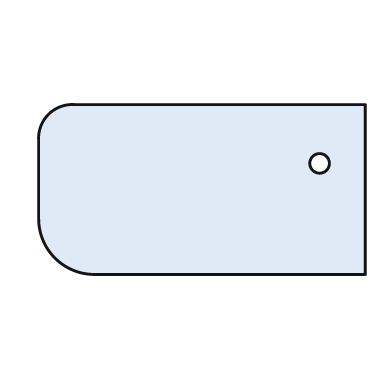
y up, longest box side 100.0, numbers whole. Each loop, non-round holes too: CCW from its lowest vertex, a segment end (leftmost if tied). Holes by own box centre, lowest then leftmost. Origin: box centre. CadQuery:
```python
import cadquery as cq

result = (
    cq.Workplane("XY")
    .moveTo(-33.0, -26.0)
    .lineTo(50.0, -26.0)
    .lineTo(50.0, 26.0)
    .lineTo(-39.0, 26.0)
    .threePointArc((-47.0, 23.0), (-50.0, 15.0))
    .lineTo(-50.0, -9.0)
    .threePointArc((-45.0, -21.0), (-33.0, -26.0))
    .close()
    .moveTo(36.0, 8.0)
    .circle(3.0)
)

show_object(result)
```